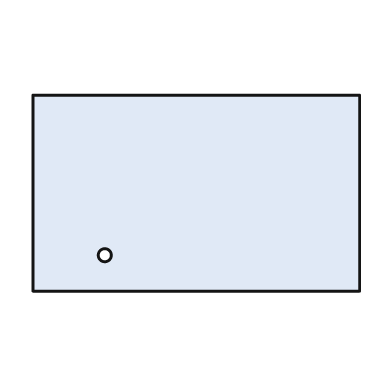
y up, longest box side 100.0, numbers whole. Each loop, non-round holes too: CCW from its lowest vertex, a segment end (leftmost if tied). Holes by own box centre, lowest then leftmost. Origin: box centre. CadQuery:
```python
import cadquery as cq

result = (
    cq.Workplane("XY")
    .moveTo(-50.0, -30.0)
    .lineTo(50.0, -30.0)
    .lineTo(50.0, 30.0)
    .lineTo(-50.0, 30.0)
    .close()
    .moveTo(-28.0, -19.0)
    .circle(2.0)
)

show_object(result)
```